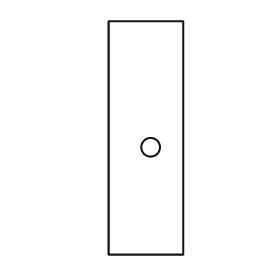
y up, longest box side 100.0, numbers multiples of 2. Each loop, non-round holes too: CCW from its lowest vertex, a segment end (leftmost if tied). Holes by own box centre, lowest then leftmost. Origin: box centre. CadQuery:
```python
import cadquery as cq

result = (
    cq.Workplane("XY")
    .moveTo(-16.0, -50.0)
    .lineTo(16.0, -50.0)
    .lineTo(16.0, 50.0)
    .lineTo(-16.0, 50.0)
    .close()
    .moveTo(2.0, -4.0)
    .circle(4.0)
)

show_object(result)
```